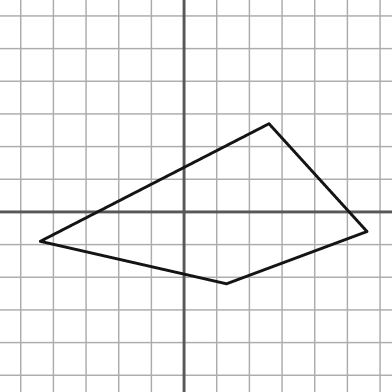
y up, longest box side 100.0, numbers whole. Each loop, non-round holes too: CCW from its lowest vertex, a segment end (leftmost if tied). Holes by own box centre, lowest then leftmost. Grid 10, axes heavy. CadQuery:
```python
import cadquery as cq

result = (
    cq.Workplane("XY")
    .moveTo(13.0, -22.0)
    .lineTo(56.0, -6.0)
    .lineTo(26.0, 27.0)
    .lineTo(-44.0, -9.0)
    .close()
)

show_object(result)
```